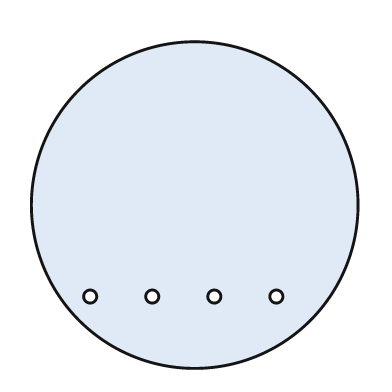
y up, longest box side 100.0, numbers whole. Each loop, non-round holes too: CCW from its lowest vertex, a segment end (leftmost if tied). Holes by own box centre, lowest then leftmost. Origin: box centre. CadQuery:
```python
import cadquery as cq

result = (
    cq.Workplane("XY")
    .moveTo(0.0, 0.0)
    .circle(50.0)
    .moveTo(-32.0, -28.0)
    .circle(2.0)
    .moveTo(-13.0, -28.0)
    .circle(2.0)
    .moveTo(6.0, -28.0)
    .circle(2.0)
    .moveTo(25.0, -28.0)
    .circle(2.0)
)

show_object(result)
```